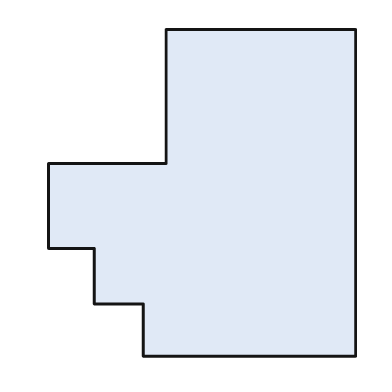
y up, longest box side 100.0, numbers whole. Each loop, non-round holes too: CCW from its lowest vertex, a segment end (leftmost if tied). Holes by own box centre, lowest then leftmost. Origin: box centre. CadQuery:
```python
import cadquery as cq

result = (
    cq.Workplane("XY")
    .moveTo(-18.0, -50.0)
    .lineTo(47.0, -50.0)
    .lineTo(47.0, 50.0)
    .lineTo(-11.0, 50.0)
    .lineTo(-11.0, 9.0)
    .lineTo(-47.0, 9.0)
    .lineTo(-47.0, -17.0)
    .lineTo(-33.0, -17.0)
    .lineTo(-33.0, -34.0)
    .lineTo(-18.0, -34.0)
    .close()
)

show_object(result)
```